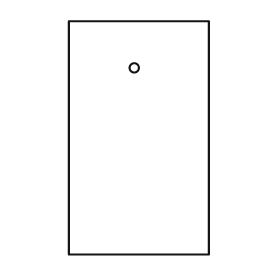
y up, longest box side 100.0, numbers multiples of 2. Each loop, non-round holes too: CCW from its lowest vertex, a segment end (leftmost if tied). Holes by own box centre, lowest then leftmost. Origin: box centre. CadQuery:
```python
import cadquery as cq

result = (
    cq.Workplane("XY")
    .moveTo(-30.0, -50.0)
    .lineTo(30.0, -50.0)
    .lineTo(30.0, 50.0)
    .lineTo(-30.0, 50.0)
    .close()
    .moveTo(-2.0, 30.0)
    .circle(2.0)
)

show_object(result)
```